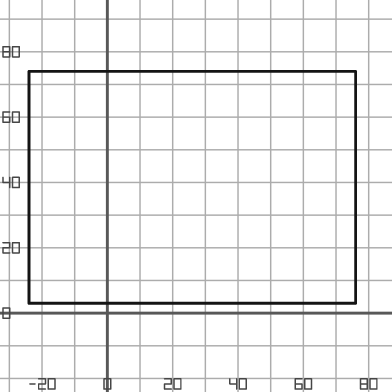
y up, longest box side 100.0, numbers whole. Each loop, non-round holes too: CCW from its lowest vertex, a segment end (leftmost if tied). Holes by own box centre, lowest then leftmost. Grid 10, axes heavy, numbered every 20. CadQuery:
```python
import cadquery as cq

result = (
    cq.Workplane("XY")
    .moveTo(-24.0, 3.0)
    .lineTo(76.0, 3.0)
    .lineTo(76.0, 74.0)
    .lineTo(-24.0, 74.0)
    .close()
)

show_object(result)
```